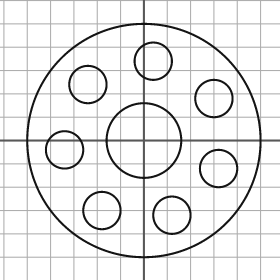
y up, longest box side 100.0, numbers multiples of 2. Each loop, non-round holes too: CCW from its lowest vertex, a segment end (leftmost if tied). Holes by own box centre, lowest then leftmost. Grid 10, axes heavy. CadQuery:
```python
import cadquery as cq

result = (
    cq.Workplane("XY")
    .moveTo(0.0, 0.0)
    .circle(50.0)
    .moveTo(12.0, -32.0)
    .circle(8.0)
    .moveTo(-18.0, -30.0)
    .circle(8.0)
    .moveTo(32.0, -12.0)
    .circle(8.0)
    .moveTo(-34.0, -4.0)
    .circle(8.0)
    .moveTo(0.0, 0.0)
    .circle(16.0)
    .moveTo(30.0, 18.0)
    .circle(8.0)
    .moveTo(-24.0, 24.0)
    .circle(8.0)
    .moveTo(4.0, 34.0)
    .circle(8.0)
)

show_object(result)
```